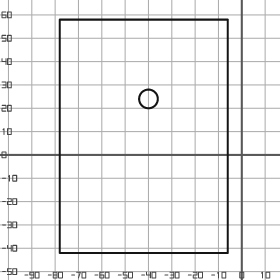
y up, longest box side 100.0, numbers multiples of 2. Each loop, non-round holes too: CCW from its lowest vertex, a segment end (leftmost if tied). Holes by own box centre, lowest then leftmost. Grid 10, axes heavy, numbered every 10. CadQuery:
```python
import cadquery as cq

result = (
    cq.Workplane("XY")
    .moveTo(-78.0, -42.0)
    .lineTo(-6.0, -42.0)
    .lineTo(-6.0, 58.0)
    .lineTo(-78.0, 58.0)
    .close()
    .moveTo(-40.0, 24.0)
    .circle(4.0)
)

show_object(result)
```